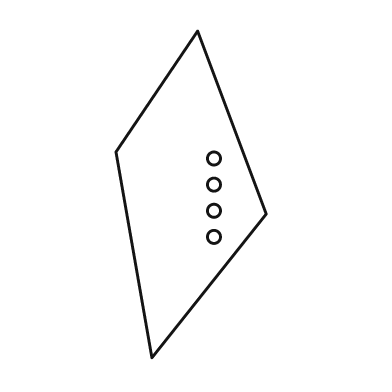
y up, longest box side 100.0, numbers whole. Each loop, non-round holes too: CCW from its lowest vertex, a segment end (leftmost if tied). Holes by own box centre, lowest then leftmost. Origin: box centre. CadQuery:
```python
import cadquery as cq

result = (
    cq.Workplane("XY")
    .moveTo(-12.0, -50.0)
    .lineTo(23.0, -6.0)
    .lineTo(2.0, 50.0)
    .lineTo(-23.0, 13.0)
    .close()
    .moveTo(7.0, -13.0)
    .circle(2.0)
    .moveTo(7.0, -5.0)
    .circle(2.0)
    .moveTo(7.0, 3.0)
    .circle(2.0)
    .moveTo(7.0, 11.0)
    .circle(2.0)
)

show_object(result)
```